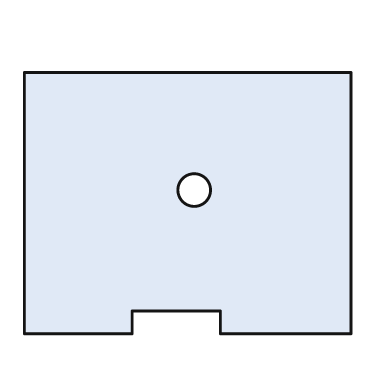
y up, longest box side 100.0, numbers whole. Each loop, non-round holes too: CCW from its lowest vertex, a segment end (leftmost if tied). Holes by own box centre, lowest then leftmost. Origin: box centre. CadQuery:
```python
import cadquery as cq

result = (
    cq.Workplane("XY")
    .moveTo(-50.0, -40.0)
    .lineTo(-17.0, -40.0)
    .lineTo(-17.0, -33.0)
    .lineTo(10.0, -33.0)
    .lineTo(10.0, -40.0)
    .lineTo(50.0, -40.0)
    .lineTo(50.0, 40.0)
    .lineTo(-50.0, 40.0)
    .close()
    .moveTo(2.0, 4.0)
    .circle(5.0)
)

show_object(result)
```